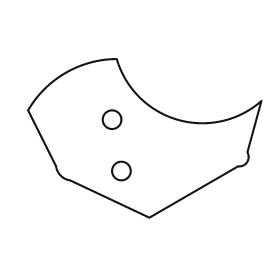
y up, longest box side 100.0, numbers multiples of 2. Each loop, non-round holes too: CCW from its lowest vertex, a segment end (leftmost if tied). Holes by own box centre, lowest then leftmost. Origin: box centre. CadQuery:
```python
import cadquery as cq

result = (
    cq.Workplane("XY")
    .moveTo(2.0, -34.0)
    .lineTo(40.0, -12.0)
    .threePointArc((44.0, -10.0), (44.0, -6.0))
    .lineTo(50.0, 16.0)
    .threePointArc((14.0, 8.0), (-12.0, 34.0))
    .threePointArc((-34.0, 28.0), (-50.0, 12.0))
    .lineTo(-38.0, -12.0)
    .threePointArc((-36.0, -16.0), (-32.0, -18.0))
    .close()
    .moveTo(-10.0, -14.0)
    .circle(4.0)
    .moveTo(-14.0, 8.0)
    .circle(4.0)
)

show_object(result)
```